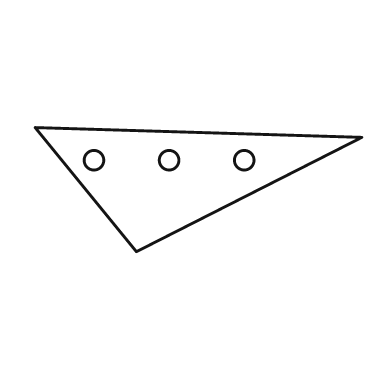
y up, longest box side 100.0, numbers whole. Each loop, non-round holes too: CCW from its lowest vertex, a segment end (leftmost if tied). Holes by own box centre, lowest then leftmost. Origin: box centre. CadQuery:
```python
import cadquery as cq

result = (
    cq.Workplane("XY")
    .moveTo(-19.0, -19.0)
    .lineTo(50.0, 16.0)
    .lineTo(-50.0, 19.0)
    .close()
    .moveTo(-32.0, 9.0)
    .circle(3.0)
    .moveTo(-9.0, 9.0)
    .circle(3.0)
    .moveTo(14.0, 9.0)
    .circle(3.0)
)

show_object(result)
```